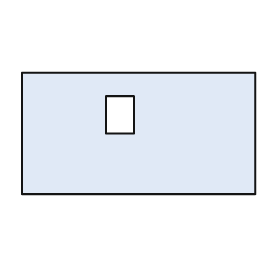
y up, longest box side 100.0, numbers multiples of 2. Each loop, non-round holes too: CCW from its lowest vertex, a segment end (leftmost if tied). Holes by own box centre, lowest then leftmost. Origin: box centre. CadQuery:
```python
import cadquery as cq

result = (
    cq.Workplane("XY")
    .moveTo(-50.0, -26.0)
    .lineTo(50.0, -26.0)
    .lineTo(50.0, 26.0)
    .lineTo(-50.0, 26.0)
    .close()
    .moveTo(-14.0, 0.0)
    .lineTo(-2.0, 0.0)
    .lineTo(-2.0, 16.0)
    .lineTo(-14.0, 16.0)
    .close()
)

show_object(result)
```